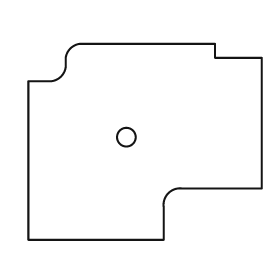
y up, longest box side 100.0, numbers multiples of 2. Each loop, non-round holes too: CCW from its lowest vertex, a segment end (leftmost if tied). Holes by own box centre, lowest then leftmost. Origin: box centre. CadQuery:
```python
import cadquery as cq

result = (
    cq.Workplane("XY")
    .moveTo(-50.0, -42.0)
    .lineTo(8.0, -42.0)
    .lineTo(8.0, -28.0)
    .threePointArc((10.0, -22.0), (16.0, -20.0))
    .lineTo(50.0, -20.0)
    .lineTo(50.0, 36.0)
    .lineTo(30.0, 36.0)
    .lineTo(30.0, 42.0)
    .lineTo(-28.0, 42.0)
    .threePointArc((-32.0, 40.0), (-34.0, 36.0))
    .lineTo(-34.0, 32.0)
    .threePointArc((-36.0, 28.0), (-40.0, 26.0))
    .lineTo(-50.0, 26.0)
    .close()
    .moveTo(-8.0, 2.0)
    .circle(4.0)
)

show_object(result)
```